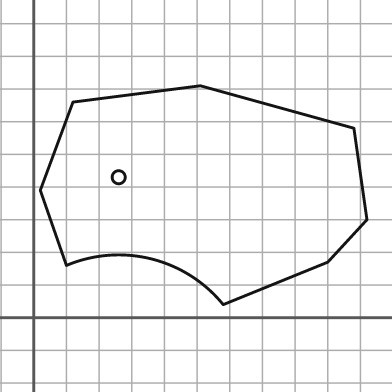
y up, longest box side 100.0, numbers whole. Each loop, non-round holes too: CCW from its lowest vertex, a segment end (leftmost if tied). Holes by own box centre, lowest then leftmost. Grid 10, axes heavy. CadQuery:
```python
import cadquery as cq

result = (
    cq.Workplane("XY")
    .moveTo(58.0, 4.0)
    .lineTo(90.0, 17.0)
    .lineTo(102.0, 30.0)
    .lineTo(98.0, 58.0)
    .lineTo(51.0, 71.0)
    .lineTo(12.0, 66.0)
    .lineTo(2.0, 39.0)
    .lineTo(10.0, 16.0)
    .threePointArc((36.0, 18.0), (58.0, 4.0))
    .close()
    .moveTo(26.0, 43.0)
    .circle(2.0)
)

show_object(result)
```